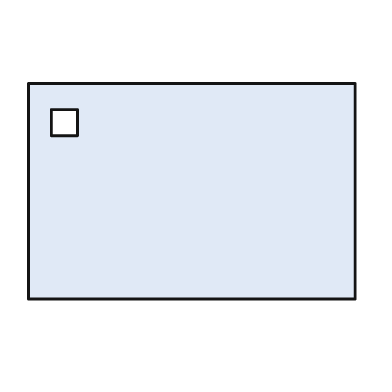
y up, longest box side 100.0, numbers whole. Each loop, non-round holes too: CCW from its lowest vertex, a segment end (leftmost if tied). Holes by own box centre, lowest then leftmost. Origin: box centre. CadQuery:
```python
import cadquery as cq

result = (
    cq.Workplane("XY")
    .moveTo(-50.0, -33.0)
    .lineTo(50.0, -33.0)
    .lineTo(50.0, 33.0)
    .lineTo(-50.0, 33.0)
    .close()
    .moveTo(-43.0, 17.0)
    .lineTo(-35.0, 17.0)
    .lineTo(-35.0, 25.0)
    .lineTo(-43.0, 25.0)
    .close()
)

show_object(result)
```